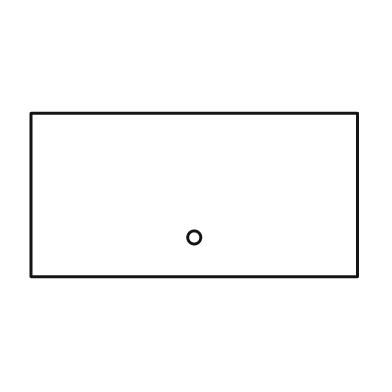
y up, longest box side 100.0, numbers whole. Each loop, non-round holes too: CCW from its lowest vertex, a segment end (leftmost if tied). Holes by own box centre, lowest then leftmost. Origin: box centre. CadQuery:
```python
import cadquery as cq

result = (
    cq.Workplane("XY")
    .moveTo(-50.0, -25.0)
    .lineTo(50.0, -25.0)
    .lineTo(50.0, 25.0)
    .lineTo(-50.0, 25.0)
    .close()
    .moveTo(0.0, -13.0)
    .circle(2.0)
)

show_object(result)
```